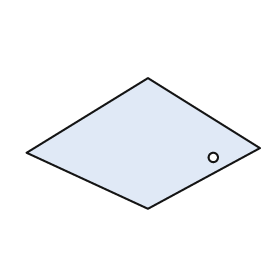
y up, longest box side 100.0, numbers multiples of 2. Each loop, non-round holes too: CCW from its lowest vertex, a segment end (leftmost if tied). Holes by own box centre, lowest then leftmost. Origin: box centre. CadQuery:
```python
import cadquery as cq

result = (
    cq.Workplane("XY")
    .moveTo(2.0, -28.0)
    .lineTo(50.0, -2.0)
    .lineTo(2.0, 28.0)
    .lineTo(-50.0, -4.0)
    .close()
    .moveTo(30.0, -6.0)
    .circle(2.0)
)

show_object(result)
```